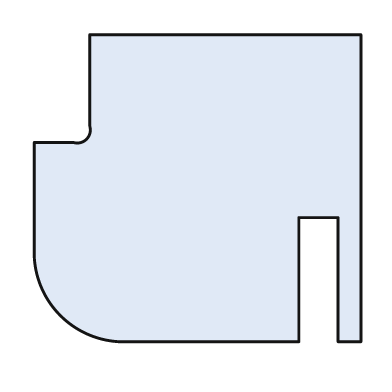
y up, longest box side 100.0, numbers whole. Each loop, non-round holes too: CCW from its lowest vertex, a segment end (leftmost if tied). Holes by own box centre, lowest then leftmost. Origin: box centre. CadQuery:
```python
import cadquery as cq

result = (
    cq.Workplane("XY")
    .moveTo(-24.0, -47.0)
    .lineTo(31.0, -47.0)
    .lineTo(31.0, -9.0)
    .lineTo(43.0, -9.0)
    .lineTo(43.0, -47.0)
    .lineTo(50.0, -47.0)
    .lineTo(50.0, 47.0)
    .lineTo(-33.0, 47.0)
    .lineTo(-33.0, 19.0)
    .threePointArc((-34.0, 15.0), (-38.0, 14.0))
    .lineTo(-50.0, 14.0)
    .lineTo(-50.0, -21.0)
    .threePointArc((-42.0, -39.0), (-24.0, -47.0))
    .close()
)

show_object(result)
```